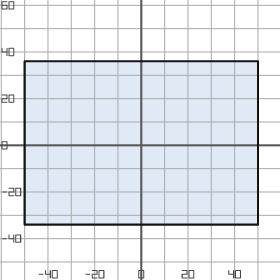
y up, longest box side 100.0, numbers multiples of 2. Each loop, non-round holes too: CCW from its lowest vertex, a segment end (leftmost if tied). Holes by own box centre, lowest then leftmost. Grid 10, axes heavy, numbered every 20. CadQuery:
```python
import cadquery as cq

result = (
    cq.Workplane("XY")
    .moveTo(-50.0, -34.0)
    .lineTo(50.0, -34.0)
    .lineTo(50.0, 36.0)
    .lineTo(-50.0, 36.0)
    .close()
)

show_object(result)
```